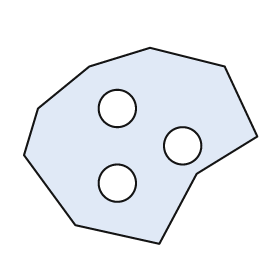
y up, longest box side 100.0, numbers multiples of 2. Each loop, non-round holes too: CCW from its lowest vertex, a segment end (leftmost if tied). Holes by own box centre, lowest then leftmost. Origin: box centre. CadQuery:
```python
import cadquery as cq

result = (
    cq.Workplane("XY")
    .moveTo(8.0, -42.0)
    .lineTo(24.0, -12.0)
    .lineTo(50.0, 4.0)
    .lineTo(36.0, 34.0)
    .lineTo(4.0, 42.0)
    .lineTo(-22.0, 34.0)
    .lineTo(-44.0, 16.0)
    .lineTo(-50.0, -4.0)
    .lineTo(-28.0, -34.0)
    .close()
    .moveTo(-10.0, -16.0)
    .circle(8.0)
    .moveTo(18.0, 0.0)
    .circle(8.0)
    .moveTo(-10.0, 16.0)
    .circle(8.0)
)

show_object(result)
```